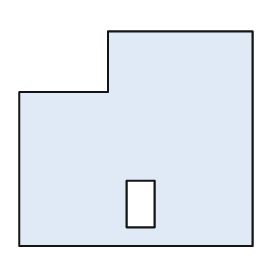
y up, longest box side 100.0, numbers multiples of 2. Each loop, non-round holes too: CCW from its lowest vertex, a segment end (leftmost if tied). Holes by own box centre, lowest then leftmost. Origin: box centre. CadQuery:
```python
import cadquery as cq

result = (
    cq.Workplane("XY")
    .moveTo(-50.0, -46.0)
    .lineTo(50.0, -46.0)
    .lineTo(50.0, 46.0)
    .lineTo(-12.0, 46.0)
    .lineTo(-12.0, 20.0)
    .lineTo(-50.0, 20.0)
    .close()
    .moveTo(-4.0, -38.0)
    .lineTo(8.0, -38.0)
    .lineTo(8.0, -18.0)
    .lineTo(-4.0, -18.0)
    .close()
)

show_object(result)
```